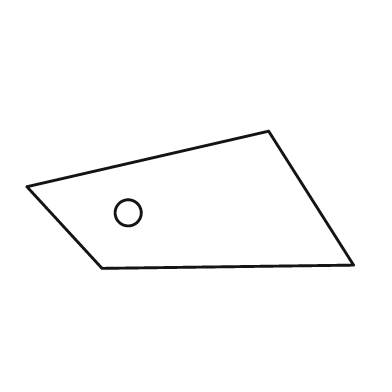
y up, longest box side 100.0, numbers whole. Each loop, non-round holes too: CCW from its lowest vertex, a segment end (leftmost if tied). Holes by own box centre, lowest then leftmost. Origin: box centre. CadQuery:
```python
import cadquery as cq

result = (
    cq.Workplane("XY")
    .moveTo(-27.0, -21.0)
    .lineTo(50.0, -20.0)
    .lineTo(24.0, 21.0)
    .lineTo(-50.0, 4.0)
    .close()
    .moveTo(-19.0, -4.0)
    .circle(4.0)
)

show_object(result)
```